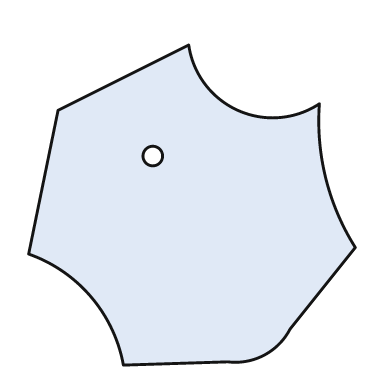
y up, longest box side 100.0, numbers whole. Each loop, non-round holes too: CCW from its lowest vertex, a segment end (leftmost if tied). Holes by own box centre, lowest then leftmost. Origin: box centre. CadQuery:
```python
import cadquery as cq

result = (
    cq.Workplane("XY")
    .moveTo(-21.0, -49.0)
    .lineTo(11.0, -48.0)
    .threePointArc((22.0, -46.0), (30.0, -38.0))
    .lineTo(50.0, -13.0)
    .threePointArc((41.0, 8.0), (39.0, 31.0))
    .threePointArc((14.0, 29.0), (-1.0, 49.0))
    .lineTo(-41.0, 29.0)
    .lineTo(-50.0, -15.0)
    .threePointArc((-31.0, -28.0), (-21.0, -49.0))
    .close()
    .moveTo(-12.0, 15.0)
    .circle(3.0)
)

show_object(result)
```